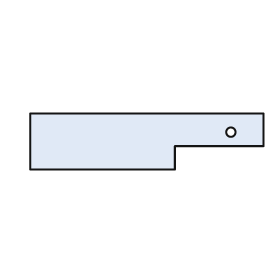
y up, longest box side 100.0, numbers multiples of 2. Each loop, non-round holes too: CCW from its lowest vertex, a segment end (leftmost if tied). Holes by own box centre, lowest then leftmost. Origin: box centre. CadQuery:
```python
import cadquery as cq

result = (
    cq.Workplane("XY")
    .moveTo(-50.0, -12.0)
    .lineTo(12.0, -12.0)
    .lineTo(12.0, -2.0)
    .lineTo(50.0, -2.0)
    .lineTo(50.0, 12.0)
    .lineTo(-50.0, 12.0)
    .close()
    .moveTo(36.0, 4.0)
    .circle(2.0)
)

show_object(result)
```